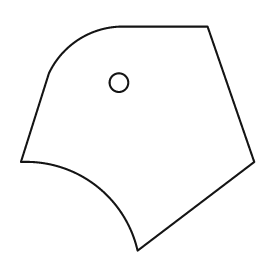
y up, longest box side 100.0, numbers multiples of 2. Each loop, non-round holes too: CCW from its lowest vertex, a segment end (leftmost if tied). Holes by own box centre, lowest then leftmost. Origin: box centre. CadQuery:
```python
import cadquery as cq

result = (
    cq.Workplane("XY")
    .moveTo(0.0, -48.0)
    .lineTo(50.0, -10.0)
    .lineTo(30.0, 48.0)
    .lineTo(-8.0, 48.0)
    .threePointArc((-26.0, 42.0), (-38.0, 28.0))
    .lineTo(-50.0, -10.0)
    .threePointArc((-18.0, -20.0), (0.0, -48.0))
    .close()
    .moveTo(-8.0, 24.0)
    .circle(4.0)
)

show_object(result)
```